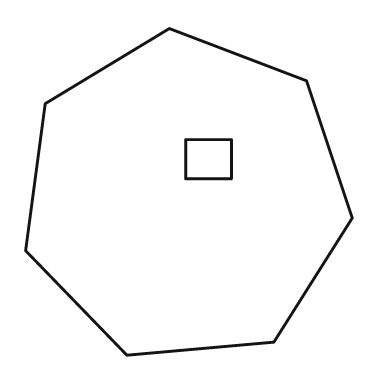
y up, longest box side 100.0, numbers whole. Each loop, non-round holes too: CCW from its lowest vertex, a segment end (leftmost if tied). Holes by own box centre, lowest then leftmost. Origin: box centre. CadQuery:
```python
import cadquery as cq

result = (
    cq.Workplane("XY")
    .moveTo(-19.0, -50.0)
    .lineTo(26.0, -46.0)
    .lineTo(50.0, -8.0)
    .lineTo(36.0, 34.0)
    .lineTo(-6.0, 50.0)
    .lineTo(-44.0, 27.0)
    .lineTo(-50.0, -18.0)
    .close()
    .moveTo(-1.0, 4.0)
    .lineTo(13.0, 4.0)
    .lineTo(13.0, 16.0)
    .lineTo(-1.0, 16.0)
    .close()
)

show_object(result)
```